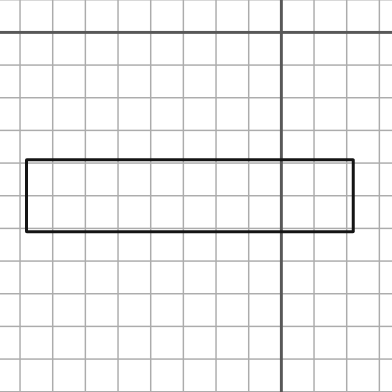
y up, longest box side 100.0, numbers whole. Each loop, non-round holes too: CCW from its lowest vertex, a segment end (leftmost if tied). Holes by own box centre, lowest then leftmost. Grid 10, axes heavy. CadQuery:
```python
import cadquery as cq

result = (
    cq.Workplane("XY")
    .moveTo(-78.0, -61.0)
    .lineTo(22.0, -61.0)
    .lineTo(22.0, -39.0)
    .lineTo(-78.0, -39.0)
    .close()
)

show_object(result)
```